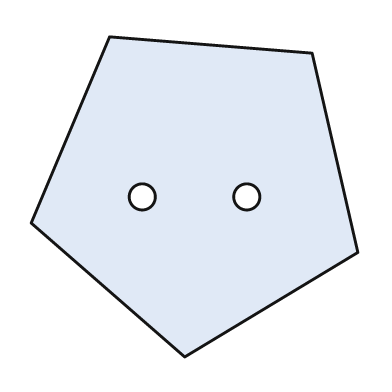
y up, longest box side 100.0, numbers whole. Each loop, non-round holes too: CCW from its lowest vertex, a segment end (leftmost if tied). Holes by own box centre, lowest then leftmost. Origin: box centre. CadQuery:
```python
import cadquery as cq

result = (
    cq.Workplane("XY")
    .moveTo(-3.0, -49.0)
    .lineTo(50.0, -17.0)
    .lineTo(36.0, 44.0)
    .lineTo(-26.0, 49.0)
    .lineTo(-50.0, -8.0)
    .close()
    .moveTo(-16.0, 0.0)
    .circle(4.0)
    .moveTo(16.0, 0.0)
    .circle(4.0)
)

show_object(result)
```